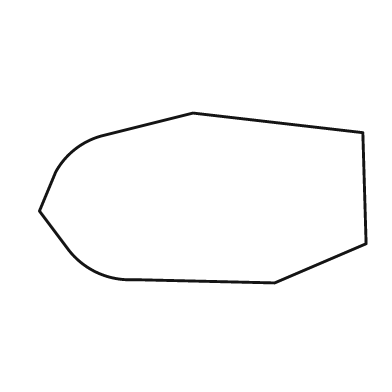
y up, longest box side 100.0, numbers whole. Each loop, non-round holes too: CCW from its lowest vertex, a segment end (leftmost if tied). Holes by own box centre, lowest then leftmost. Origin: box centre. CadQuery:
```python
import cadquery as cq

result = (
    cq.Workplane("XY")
    .moveTo(22.0, -26.0)
    .lineTo(50.0, -14.0)
    .lineTo(49.0, 20.0)
    .lineTo(-3.0, 26.0)
    .lineTo(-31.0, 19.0)
    .threePointArc((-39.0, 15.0), (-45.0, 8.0))
    .lineTo(-50.0, -4.0)
    .lineTo(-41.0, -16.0)
    .threePointArc((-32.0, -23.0), (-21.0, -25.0))
    .close()
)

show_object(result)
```